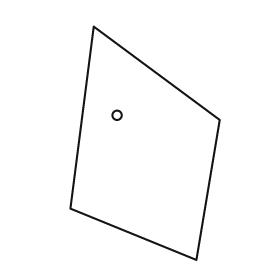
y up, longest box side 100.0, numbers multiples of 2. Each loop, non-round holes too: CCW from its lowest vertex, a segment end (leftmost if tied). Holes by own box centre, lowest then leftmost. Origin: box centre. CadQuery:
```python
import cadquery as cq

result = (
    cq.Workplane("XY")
    .moveTo(22.0, -50.0)
    .lineTo(32.0, 10.0)
    .lineTo(-22.0, 50.0)
    .lineTo(-32.0, -28.0)
    .close()
    .moveTo(-12.0, 12.0)
    .circle(2.0)
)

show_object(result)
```